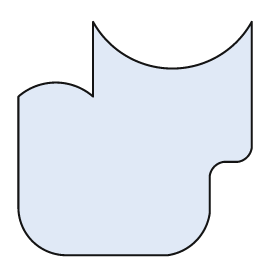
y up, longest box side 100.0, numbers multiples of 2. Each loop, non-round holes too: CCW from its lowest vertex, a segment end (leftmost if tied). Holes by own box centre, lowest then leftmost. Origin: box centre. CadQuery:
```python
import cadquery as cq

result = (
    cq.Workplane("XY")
    .moveTo(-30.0, -50.0)
    .lineTo(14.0, -50.0)
    .threePointArc((26.0, -44.0), (32.0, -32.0))
    .lineTo(32.0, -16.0)
    .threePointArc((34.0, -12.0), (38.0, -10.0))
    .lineTo(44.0, -10.0)
    .threePointArc((48.0, -8.0), (50.0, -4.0))
    .lineTo(50.0, 50.0)
    .threePointArc((16.0, 30.0), (-18.0, 50.0))
    .lineTo(-18.0, 18.0)
    .threePointArc((-34.0, 24.0), (-50.0, 18.0))
    .lineTo(-50.0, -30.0)
    .threePointArc((-44.0, -44.0), (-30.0, -50.0))
    .close()
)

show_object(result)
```